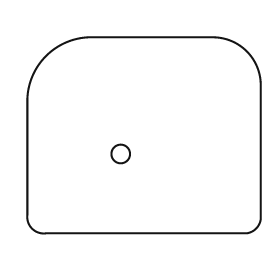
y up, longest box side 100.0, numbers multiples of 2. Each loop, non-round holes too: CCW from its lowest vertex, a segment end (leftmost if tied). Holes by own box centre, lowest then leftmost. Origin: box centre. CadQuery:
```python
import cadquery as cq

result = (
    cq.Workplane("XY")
    .moveTo(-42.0, -42.0)
    .lineTo(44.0, -42.0)
    .threePointArc((48.0, -40.0), (50.0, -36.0))
    .lineTo(50.0, 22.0)
    .threePointArc((44.0, 36.0), (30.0, 42.0))
    .lineTo(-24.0, 42.0)
    .threePointArc((-42.0, 34.0), (-50.0, 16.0))
    .lineTo(-50.0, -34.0)
    .threePointArc((-48.0, -40.0), (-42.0, -42.0))
    .close()
    .moveTo(-10.0, -8.0)
    .circle(4.0)
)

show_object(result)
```